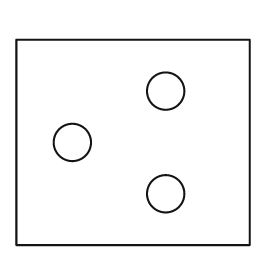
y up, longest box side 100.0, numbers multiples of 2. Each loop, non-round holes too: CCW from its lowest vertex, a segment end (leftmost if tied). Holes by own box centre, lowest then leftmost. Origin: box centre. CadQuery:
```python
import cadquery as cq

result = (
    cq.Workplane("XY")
    .moveTo(-50.0, -44.0)
    .lineTo(50.0, -44.0)
    .lineTo(50.0, 44.0)
    .lineTo(-50.0, 44.0)
    .close()
    .moveTo(14.0, -22.0)
    .circle(8.0)
    .moveTo(-26.0, 0.0)
    .circle(8.0)
    .moveTo(14.0, 22.0)
    .circle(8.0)
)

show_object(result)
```